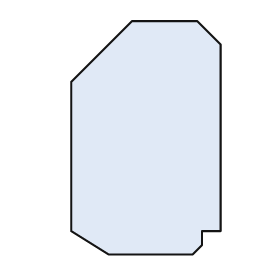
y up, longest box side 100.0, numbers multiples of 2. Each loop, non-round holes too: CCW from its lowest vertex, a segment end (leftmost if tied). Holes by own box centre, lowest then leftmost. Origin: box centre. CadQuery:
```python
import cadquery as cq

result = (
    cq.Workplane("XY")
    .moveTo(-16.0, -50.0)
    .lineTo(20.0, -50.0)
    .lineTo(24.0, -46.0)
    .lineTo(24.0, -40.0)
    .lineTo(32.0, -40.0)
    .lineTo(32.0, 40.0)
    .lineTo(22.0, 50.0)
    .lineTo(-6.0, 50.0)
    .lineTo(-32.0, 24.0)
    .lineTo(-32.0, -40.0)
    .close()
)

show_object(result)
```